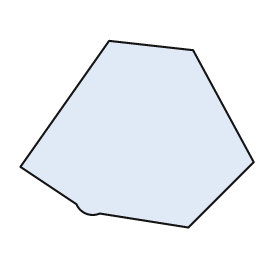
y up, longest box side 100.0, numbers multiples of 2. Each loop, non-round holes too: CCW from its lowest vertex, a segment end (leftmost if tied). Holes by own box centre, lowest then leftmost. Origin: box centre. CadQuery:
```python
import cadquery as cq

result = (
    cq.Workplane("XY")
    .moveTo(22.0, -40.0)
    .lineTo(50.0, -12.0)
    .lineTo(24.0, 36.0)
    .lineTo(-12.0, 40.0)
    .lineTo(-50.0, -14.0)
    .lineTo(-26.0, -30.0)
    .threePointArc((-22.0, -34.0), (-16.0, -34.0))
    .close()
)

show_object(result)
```